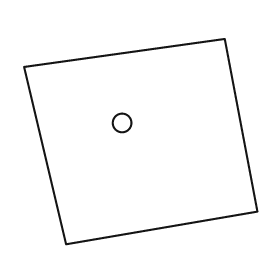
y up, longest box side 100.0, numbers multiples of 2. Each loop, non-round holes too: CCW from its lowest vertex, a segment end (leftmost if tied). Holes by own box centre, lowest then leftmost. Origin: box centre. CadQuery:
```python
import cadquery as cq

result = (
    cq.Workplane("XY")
    .moveTo(-32.0, -44.0)
    .lineTo(50.0, -30.0)
    .lineTo(36.0, 44.0)
    .lineTo(-50.0, 32.0)
    .close()
    .moveTo(-8.0, 8.0)
    .circle(4.0)
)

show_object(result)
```